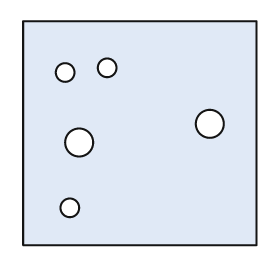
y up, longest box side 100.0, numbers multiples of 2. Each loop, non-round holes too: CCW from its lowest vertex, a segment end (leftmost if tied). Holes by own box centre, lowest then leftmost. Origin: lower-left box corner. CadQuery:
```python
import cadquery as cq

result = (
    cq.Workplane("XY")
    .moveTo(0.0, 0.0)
    .lineTo(100.0, 0.0)
    .lineTo(100.0, 96.0)
    .lineTo(0.0, 96.0)
    .close()
    .moveTo(20.0, 16.0)
    .circle(4.0)
    .moveTo(24.0, 44.0)
    .circle(6.0)
    .moveTo(80.0, 52.0)
    .circle(6.0)
    .moveTo(18.0, 74.0)
    .circle(4.0)
    .moveTo(36.0, 76.0)
    .circle(4.0)
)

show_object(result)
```